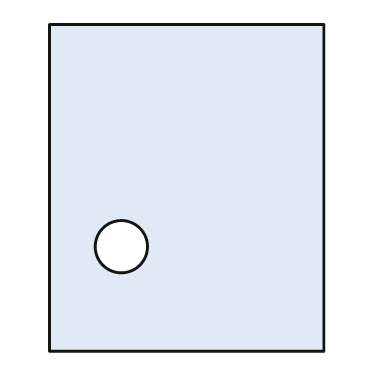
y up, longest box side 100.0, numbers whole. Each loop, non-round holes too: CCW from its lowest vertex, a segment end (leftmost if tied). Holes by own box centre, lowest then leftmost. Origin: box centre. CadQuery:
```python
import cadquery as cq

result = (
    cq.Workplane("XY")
    .moveTo(-42.0, -50.0)
    .lineTo(42.0, -50.0)
    .lineTo(42.0, 50.0)
    .lineTo(-42.0, 50.0)
    .close()
    .moveTo(-20.0, -18.0)
    .circle(8.0)
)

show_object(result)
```